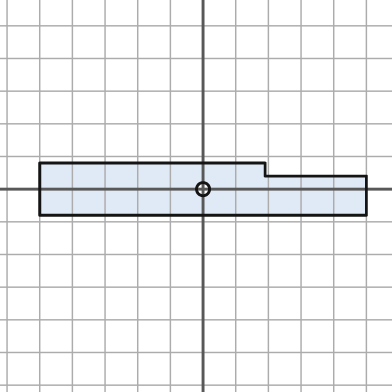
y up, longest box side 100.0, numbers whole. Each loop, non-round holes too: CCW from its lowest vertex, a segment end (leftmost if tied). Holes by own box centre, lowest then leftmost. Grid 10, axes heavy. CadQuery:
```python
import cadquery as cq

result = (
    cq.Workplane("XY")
    .moveTo(-50.0, -8.0)
    .lineTo(50.0, -8.0)
    .lineTo(50.0, 4.0)
    .lineTo(19.0, 4.0)
    .lineTo(19.0, 8.0)
    .lineTo(-50.0, 8.0)
    .close()
    .moveTo(0.0, 0.0)
    .circle(2.0)
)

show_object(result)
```